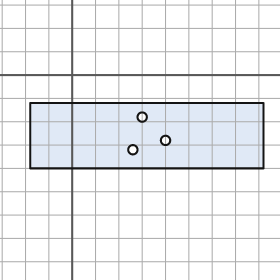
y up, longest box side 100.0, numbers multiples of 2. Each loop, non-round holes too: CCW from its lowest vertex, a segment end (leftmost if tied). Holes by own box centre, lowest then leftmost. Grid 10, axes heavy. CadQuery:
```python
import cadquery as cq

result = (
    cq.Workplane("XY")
    .moveTo(-18.0, -40.0)
    .lineTo(82.0, -40.0)
    .lineTo(82.0, -12.0)
    .lineTo(-18.0, -12.0)
    .close()
    .moveTo(26.0, -32.0)
    .circle(2.0)
    .moveTo(40.0, -28.0)
    .circle(2.0)
    .moveTo(30.0, -18.0)
    .circle(2.0)
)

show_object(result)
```